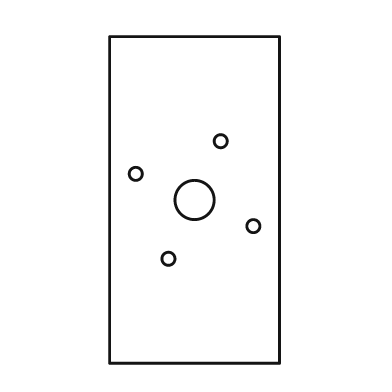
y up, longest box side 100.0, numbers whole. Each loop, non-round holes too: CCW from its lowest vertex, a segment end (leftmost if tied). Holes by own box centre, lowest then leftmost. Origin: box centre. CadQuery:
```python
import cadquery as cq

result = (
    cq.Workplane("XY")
    .moveTo(-26.0, -50.0)
    .lineTo(26.0, -50.0)
    .lineTo(26.0, 50.0)
    .lineTo(-26.0, 50.0)
    .close()
    .moveTo(-8.0, -18.0)
    .circle(2.0)
    .moveTo(18.0, -8.0)
    .circle(2.0)
    .moveTo(0.0, 0.0)
    .circle(6.0)
    .moveTo(-18.0, 8.0)
    .circle(2.0)
    .moveTo(8.0, 18.0)
    .circle(2.0)
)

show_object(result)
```